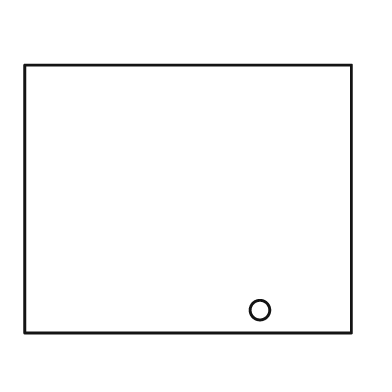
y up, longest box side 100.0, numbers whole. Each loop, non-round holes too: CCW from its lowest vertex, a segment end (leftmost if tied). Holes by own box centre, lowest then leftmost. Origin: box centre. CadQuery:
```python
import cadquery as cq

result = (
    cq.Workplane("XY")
    .moveTo(-50.0, -41.0)
    .lineTo(50.0, -41.0)
    .lineTo(50.0, 41.0)
    .lineTo(-50.0, 41.0)
    .close()
    .moveTo(22.0, -34.0)
    .circle(3.0)
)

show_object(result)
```